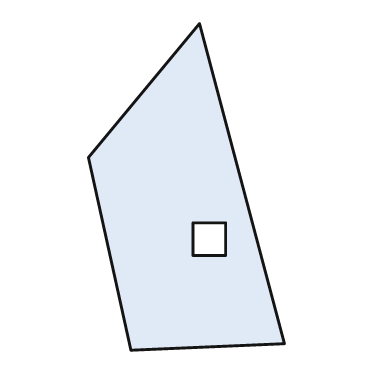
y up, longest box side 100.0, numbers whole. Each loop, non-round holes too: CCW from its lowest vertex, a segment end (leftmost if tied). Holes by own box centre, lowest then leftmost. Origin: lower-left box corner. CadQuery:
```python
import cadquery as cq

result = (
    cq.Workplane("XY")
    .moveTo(13.0, 0.0)
    .lineTo(60.0, 2.0)
    .lineTo(34.0, 100.0)
    .lineTo(0.0, 59.0)
    .close()
    .moveTo(32.0, 29.0)
    .lineTo(42.0, 29.0)
    .lineTo(42.0, 39.0)
    .lineTo(32.0, 39.0)
    .close()
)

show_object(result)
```